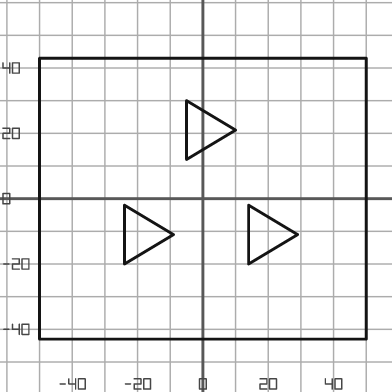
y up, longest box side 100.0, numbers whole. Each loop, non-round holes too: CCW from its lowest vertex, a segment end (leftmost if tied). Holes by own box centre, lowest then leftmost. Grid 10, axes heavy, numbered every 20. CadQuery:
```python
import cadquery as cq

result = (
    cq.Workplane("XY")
    .moveTo(-50.0, -43.0)
    .lineTo(50.0, -43.0)
    .lineTo(50.0, 43.0)
    .lineTo(-50.0, 43.0)
    .close()
    .moveTo(-24.0, -20.0)
    .lineTo(-9.0, -11.0)
    .lineTo(-24.0, -2.0)
    .close()
    .moveTo(14.0, -20.0)
    .lineTo(29.0, -11.0)
    .lineTo(14.0, -2.0)
    .close()
    .moveTo(-5.0, 12.0)
    .lineTo(10.0, 21.0)
    .lineTo(-5.0, 30.0)
    .close()
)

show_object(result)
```